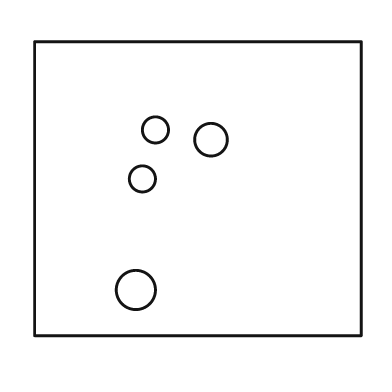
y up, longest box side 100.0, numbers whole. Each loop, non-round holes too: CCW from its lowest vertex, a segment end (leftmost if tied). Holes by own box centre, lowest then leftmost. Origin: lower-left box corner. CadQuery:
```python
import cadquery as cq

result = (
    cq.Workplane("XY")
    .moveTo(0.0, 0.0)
    .lineTo(100.0, 0.0)
    .lineTo(100.0, 90.0)
    .lineTo(0.0, 90.0)
    .close()
    .moveTo(31.0, 14.0)
    .circle(6.0)
    .moveTo(33.0, 48.0)
    .circle(4.0)
    .moveTo(54.0, 60.0)
    .circle(5.0)
    .moveTo(37.0, 63.0)
    .circle(4.0)
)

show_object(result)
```